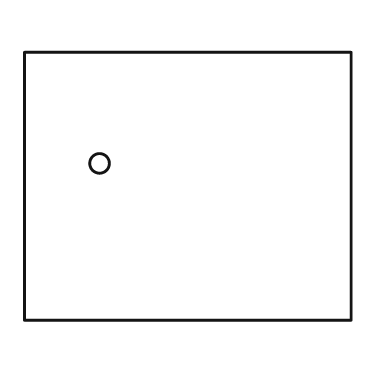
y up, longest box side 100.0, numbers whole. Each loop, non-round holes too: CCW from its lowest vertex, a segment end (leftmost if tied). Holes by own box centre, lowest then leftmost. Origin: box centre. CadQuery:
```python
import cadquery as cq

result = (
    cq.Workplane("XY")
    .moveTo(-50.0, -41.0)
    .lineTo(50.0, -41.0)
    .lineTo(50.0, 41.0)
    .lineTo(-50.0, 41.0)
    .close()
    .moveTo(-27.0, 7.0)
    .circle(3.0)
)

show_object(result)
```